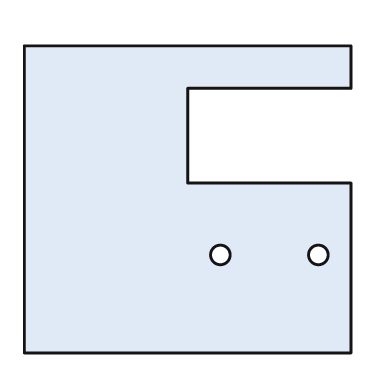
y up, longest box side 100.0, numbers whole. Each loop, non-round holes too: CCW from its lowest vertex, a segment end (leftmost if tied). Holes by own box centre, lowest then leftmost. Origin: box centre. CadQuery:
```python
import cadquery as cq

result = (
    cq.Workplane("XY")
    .moveTo(-50.0, -47.0)
    .lineTo(50.0, -47.0)
    .lineTo(50.0, 5.0)
    .lineTo(0.0, 5.0)
    .lineTo(0.0, 34.0)
    .lineTo(50.0, 34.0)
    .lineTo(50.0, 47.0)
    .lineTo(-50.0, 47.0)
    .close()
    .moveTo(10.0, -17.0)
    .circle(3.0)
    .moveTo(40.0, -17.0)
    .circle(3.0)
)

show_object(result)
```